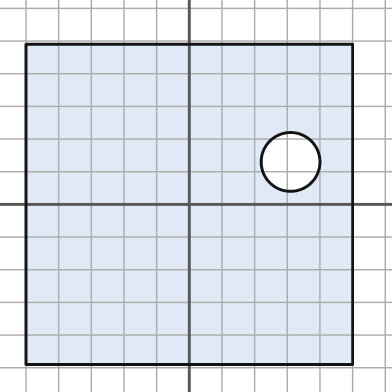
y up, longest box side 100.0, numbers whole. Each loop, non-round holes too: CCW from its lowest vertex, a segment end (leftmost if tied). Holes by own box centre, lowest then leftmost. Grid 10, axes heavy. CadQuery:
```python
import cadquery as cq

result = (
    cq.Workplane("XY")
    .moveTo(-50.0, -49.0)
    .lineTo(50.0, -49.0)
    .lineTo(50.0, 49.0)
    .lineTo(-50.0, 49.0)
    .close()
    .moveTo(31.0, 13.0)
    .circle(9.0)
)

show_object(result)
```